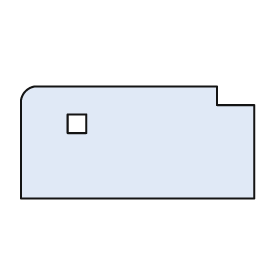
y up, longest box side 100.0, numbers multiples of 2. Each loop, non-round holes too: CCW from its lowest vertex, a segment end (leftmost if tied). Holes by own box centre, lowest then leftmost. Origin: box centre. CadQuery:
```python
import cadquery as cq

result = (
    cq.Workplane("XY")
    .moveTo(-50.0, -24.0)
    .lineTo(50.0, -24.0)
    .lineTo(50.0, 16.0)
    .lineTo(34.0, 16.0)
    .lineTo(34.0, 24.0)
    .lineTo(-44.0, 24.0)
    .threePointArc((-48.0, 22.0), (-50.0, 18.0))
    .close()
    .moveTo(-30.0, 4.0)
    .lineTo(-22.0, 4.0)
    .lineTo(-22.0, 12.0)
    .lineTo(-30.0, 12.0)
    .close()
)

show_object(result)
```